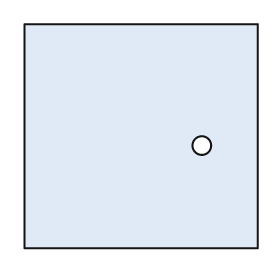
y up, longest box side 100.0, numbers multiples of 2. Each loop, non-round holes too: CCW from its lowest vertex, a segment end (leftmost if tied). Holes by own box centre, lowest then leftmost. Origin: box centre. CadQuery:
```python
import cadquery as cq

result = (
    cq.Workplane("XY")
    .moveTo(-50.0, -48.0)
    .lineTo(50.0, -48.0)
    .lineTo(50.0, 48.0)
    .lineTo(-50.0, 48.0)
    .close()
    .moveTo(26.0, -4.0)
    .circle(4.0)
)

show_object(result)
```